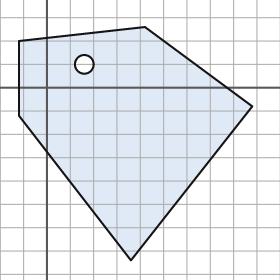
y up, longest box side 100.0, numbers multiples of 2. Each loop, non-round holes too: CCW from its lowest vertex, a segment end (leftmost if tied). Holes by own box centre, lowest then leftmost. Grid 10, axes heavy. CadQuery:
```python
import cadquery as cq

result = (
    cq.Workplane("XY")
    .moveTo(36.0, -74.0)
    .lineTo(88.0, -8.0)
    .lineTo(42.0, 26.0)
    .lineTo(-12.0, 20.0)
    .lineTo(-12.0, -12.0)
    .close()
    .moveTo(16.0, 10.0)
    .circle(4.0)
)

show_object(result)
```